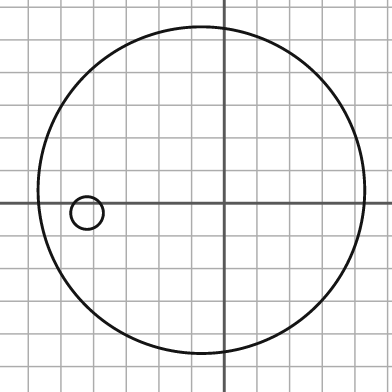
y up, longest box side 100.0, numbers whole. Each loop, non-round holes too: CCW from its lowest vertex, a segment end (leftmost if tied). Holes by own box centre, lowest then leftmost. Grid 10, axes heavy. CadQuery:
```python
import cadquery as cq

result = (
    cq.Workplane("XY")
    .moveTo(-7.0, 4.0)
    .circle(50.0)
    .moveTo(-42.0, -3.0)
    .circle(5.0)
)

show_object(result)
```